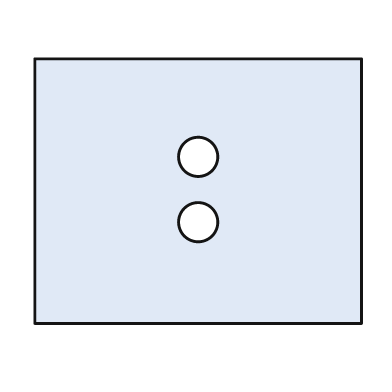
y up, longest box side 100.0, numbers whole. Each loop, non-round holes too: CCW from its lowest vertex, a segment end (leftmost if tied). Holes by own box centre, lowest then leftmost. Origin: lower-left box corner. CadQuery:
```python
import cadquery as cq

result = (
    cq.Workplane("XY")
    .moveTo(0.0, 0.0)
    .lineTo(100.0, 0.0)
    .lineTo(100.0, 81.0)
    .lineTo(0.0, 81.0)
    .close()
    .moveTo(50.0, 31.0)
    .circle(6.0)
    .moveTo(50.0, 51.0)
    .circle(6.0)
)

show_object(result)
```